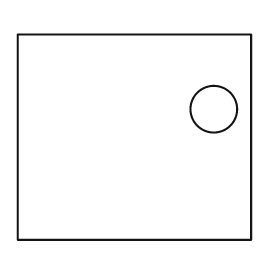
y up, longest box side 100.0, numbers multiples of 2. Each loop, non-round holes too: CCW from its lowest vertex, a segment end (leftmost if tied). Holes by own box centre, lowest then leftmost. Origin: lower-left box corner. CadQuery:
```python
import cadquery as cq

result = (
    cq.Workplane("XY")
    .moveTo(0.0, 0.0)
    .lineTo(100.0, 0.0)
    .lineTo(100.0, 88.0)
    .lineTo(0.0, 88.0)
    .close()
    .moveTo(84.0, 56.0)
    .circle(10.0)
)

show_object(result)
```